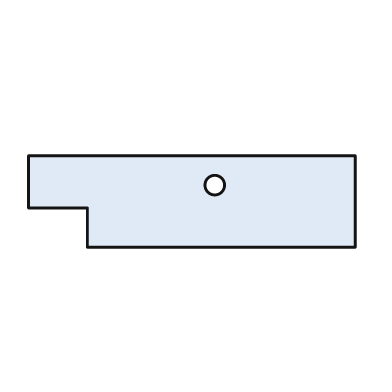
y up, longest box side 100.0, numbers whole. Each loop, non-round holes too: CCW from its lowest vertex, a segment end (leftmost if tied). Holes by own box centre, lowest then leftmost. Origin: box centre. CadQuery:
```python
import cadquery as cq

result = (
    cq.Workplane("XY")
    .moveTo(-32.0, -14.0)
    .lineTo(50.0, -14.0)
    .lineTo(50.0, 14.0)
    .lineTo(-50.0, 14.0)
    .lineTo(-50.0, -2.0)
    .lineTo(-32.0, -2.0)
    .close()
    .moveTo(7.0, 5.0)
    .circle(3.0)
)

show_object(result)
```